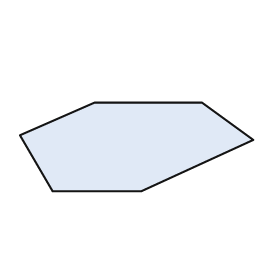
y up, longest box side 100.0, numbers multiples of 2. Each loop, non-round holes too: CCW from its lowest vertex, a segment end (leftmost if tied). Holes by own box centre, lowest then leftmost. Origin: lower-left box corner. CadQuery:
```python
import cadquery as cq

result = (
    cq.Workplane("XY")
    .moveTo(14.0, 0.0)
    .lineTo(52.0, 0.0)
    .lineTo(100.0, 22.0)
    .lineTo(78.0, 38.0)
    .lineTo(32.0, 38.0)
    .lineTo(0.0, 24.0)
    .close()
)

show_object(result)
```